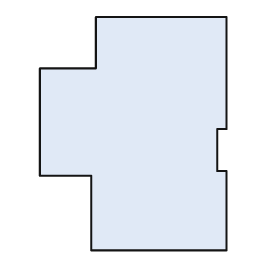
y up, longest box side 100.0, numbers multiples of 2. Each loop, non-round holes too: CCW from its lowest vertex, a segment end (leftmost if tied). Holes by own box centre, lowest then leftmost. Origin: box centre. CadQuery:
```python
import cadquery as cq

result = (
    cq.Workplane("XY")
    .moveTo(-18.0, -50.0)
    .lineTo(40.0, -50.0)
    .lineTo(40.0, -16.0)
    .lineTo(36.0, -16.0)
    .lineTo(36.0, 2.0)
    .lineTo(40.0, 2.0)
    .lineTo(40.0, 50.0)
    .lineTo(-16.0, 50.0)
    .lineTo(-16.0, 28.0)
    .lineTo(-40.0, 28.0)
    .lineTo(-40.0, -18.0)
    .lineTo(-18.0, -18.0)
    .close()
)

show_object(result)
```